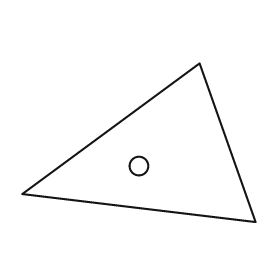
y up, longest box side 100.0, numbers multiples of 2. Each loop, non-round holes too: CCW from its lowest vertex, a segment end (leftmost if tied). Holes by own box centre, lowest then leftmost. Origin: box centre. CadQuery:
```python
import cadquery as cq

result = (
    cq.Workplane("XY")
    .moveTo(50.0, -34.0)
    .lineTo(26.0, 34.0)
    .lineTo(-50.0, -22.0)
    .close()
    .moveTo(0.0, -10.0)
    .circle(4.0)
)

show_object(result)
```